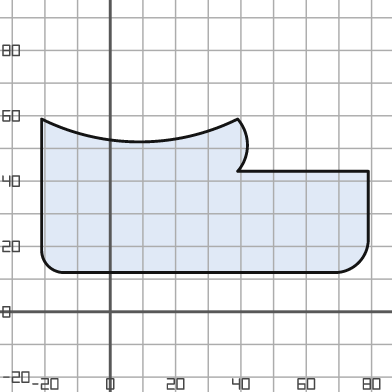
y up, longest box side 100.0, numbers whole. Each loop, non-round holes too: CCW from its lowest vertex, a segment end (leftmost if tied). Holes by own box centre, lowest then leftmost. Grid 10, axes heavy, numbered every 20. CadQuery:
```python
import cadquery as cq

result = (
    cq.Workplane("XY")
    .moveTo(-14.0, 12.0)
    .lineTo(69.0, 12.0)
    .threePointArc((76.0, 15.0), (79.0, 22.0))
    .lineTo(79.0, 43.0)
    .lineTo(39.0, 43.0)
    .threePointArc((42.0, 51.0), (39.0, 59.0))
    .threePointArc((9.0, 52.0), (-21.0, 59.0))
    .lineTo(-21.0, 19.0)
    .threePointArc((-19.0, 14.0), (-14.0, 12.0))
    .close()
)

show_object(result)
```